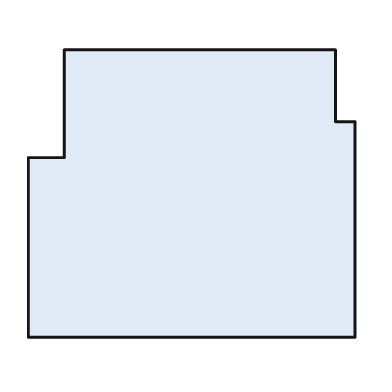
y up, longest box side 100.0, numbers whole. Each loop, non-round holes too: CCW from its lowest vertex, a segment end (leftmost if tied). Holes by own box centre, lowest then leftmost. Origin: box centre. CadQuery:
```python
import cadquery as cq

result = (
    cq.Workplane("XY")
    .moveTo(-50.0, -44.0)
    .lineTo(50.0, -44.0)
    .lineTo(50.0, 22.0)
    .lineTo(44.0, 22.0)
    .lineTo(44.0, 44.0)
    .lineTo(-39.0, 44.0)
    .lineTo(-39.0, 11.0)
    .lineTo(-50.0, 11.0)
    .close()
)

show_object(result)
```